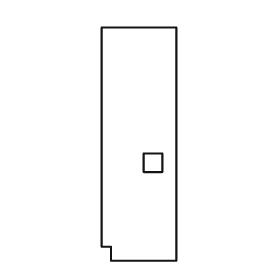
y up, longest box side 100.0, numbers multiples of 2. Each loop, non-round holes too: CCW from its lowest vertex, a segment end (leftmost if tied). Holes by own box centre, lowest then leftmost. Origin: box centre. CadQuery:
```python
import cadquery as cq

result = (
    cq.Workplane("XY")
    .moveTo(-12.0, -50.0)
    .lineTo(16.0, -50.0)
    .lineTo(16.0, 50.0)
    .lineTo(-16.0, 50.0)
    .lineTo(-16.0, -44.0)
    .lineTo(-12.0, -44.0)
    .close()
    .moveTo(2.0, -12.0)
    .lineTo(10.0, -12.0)
    .lineTo(10.0, -4.0)
    .lineTo(2.0, -4.0)
    .close()
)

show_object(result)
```